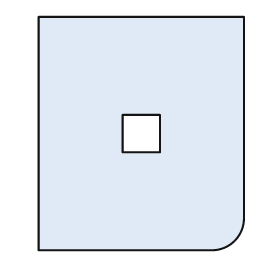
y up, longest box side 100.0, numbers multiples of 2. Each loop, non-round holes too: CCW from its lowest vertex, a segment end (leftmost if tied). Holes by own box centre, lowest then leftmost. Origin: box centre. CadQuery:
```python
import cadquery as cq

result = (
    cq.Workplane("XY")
    .moveTo(-44.0, -50.0)
    .lineTo(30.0, -50.0)
    .threePointArc((40.0, -46.0), (44.0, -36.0))
    .lineTo(44.0, 50.0)
    .lineTo(-44.0, 50.0)
    .close()
    .moveTo(-8.0, -8.0)
    .lineTo(8.0, -8.0)
    .lineTo(8.0, 8.0)
    .lineTo(-8.0, 8.0)
    .close()
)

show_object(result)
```